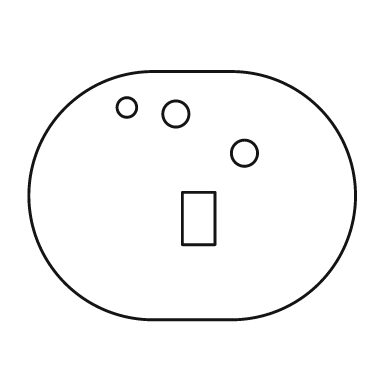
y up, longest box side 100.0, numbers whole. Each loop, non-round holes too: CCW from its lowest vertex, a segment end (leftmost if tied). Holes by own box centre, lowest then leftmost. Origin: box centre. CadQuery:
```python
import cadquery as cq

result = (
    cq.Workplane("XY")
    .moveTo(-12.0, -38.0)
    .lineTo(12.0, -38.0)
    .threePointArc((50.0, 0.0), (12.0, 38.0))
    .lineTo(-12.0, 38.0)
    .threePointArc((-50.0, 0.0), (-12.0, -38.0))
    .close()
    .moveTo(-3.0, -15.0)
    .lineTo(7.0, -15.0)
    .lineTo(7.0, 1.0)
    .lineTo(-3.0, 1.0)
    .close()
    .moveTo(16.0, 13.0)
    .circle(4.0)
    .moveTo(-5.0, 25.0)
    .circle(4.0)
    .moveTo(-20.0, 27.0)
    .circle(3.0)
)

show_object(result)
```